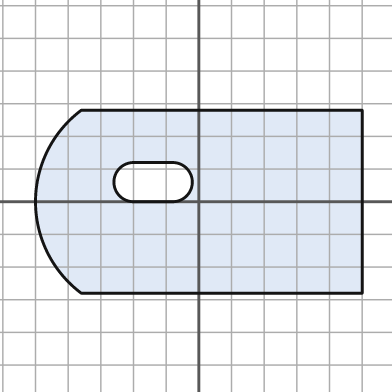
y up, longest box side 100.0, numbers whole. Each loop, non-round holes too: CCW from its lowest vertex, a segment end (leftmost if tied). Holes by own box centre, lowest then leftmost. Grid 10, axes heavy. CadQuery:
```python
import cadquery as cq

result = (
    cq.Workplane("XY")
    .moveTo(-36.0, -28.0)
    .lineTo(50.0, -28.0)
    .lineTo(50.0, 28.0)
    .lineTo(-36.0, 28.0)
    .threePointArc((-50.0, 0.0), (-36.0, -28.0))
    .close()
    .moveTo(-20.0, 0.0)
    .lineTo(-8.0, 0.0)
    .threePointArc((-2.0, 6.0), (-8.0, 12.0))
    .lineTo(-20.0, 12.0)
    .threePointArc((-26.0, 6.0), (-20.0, 0.0))
    .close()
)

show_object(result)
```